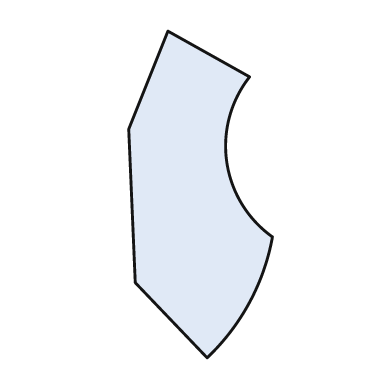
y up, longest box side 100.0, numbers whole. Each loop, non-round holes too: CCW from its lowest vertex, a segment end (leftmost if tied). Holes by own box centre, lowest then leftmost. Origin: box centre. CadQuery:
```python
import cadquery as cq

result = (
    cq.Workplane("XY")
    .moveTo(2.0, -50.0)
    .threePointArc((15.0, -33.0), (22.0, -13.0))
    .threePointArc((8.0, 10.0), (15.0, 36.0))
    .lineTo(-10.0, 50.0)
    .lineTo(-22.0, 20.0)
    .lineTo(-20.0, -27.0)
    .close()
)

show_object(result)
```